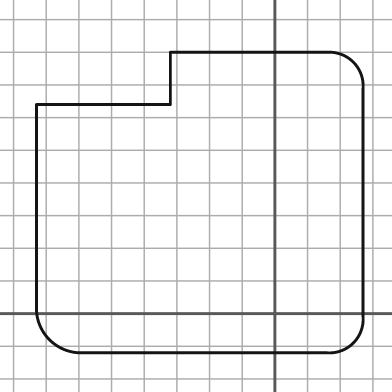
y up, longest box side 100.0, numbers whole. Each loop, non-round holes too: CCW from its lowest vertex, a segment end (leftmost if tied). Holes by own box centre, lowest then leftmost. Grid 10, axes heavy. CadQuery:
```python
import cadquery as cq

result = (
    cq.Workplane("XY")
    .moveTo(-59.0, -12.0)
    .lineTo(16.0, -12.0)
    .threePointArc((24.0, -9.0), (27.0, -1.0))
    .lineTo(27.0, 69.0)
    .threePointArc((24.0, 77.0), (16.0, 80.0))
    .lineTo(-32.0, 80.0)
    .lineTo(-32.0, 64.0)
    .lineTo(-73.0, 64.0)
    .lineTo(-73.0, 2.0)
    .threePointArc((-69.0, -8.0), (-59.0, -12.0))
    .close()
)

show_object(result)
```